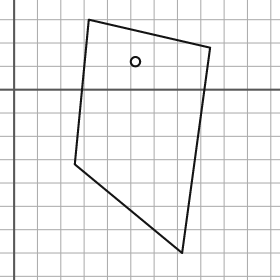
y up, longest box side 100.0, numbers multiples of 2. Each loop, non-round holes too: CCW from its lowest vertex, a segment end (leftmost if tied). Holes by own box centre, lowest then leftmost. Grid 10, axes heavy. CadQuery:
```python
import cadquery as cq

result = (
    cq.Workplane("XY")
    .moveTo(72.0, -70.0)
    .lineTo(84.0, 18.0)
    .lineTo(32.0, 30.0)
    .lineTo(26.0, -32.0)
    .close()
    .moveTo(52.0, 12.0)
    .circle(2.0)
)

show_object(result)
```